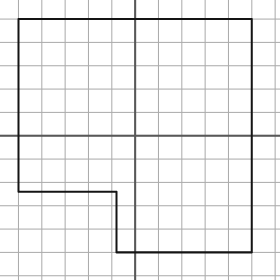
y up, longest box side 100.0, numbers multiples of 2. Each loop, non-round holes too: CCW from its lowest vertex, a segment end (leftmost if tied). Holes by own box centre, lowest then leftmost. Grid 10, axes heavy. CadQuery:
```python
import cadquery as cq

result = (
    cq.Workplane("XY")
    .moveTo(-8.0, -50.0)
    .lineTo(50.0, -50.0)
    .lineTo(50.0, 50.0)
    .lineTo(-50.0, 50.0)
    .lineTo(-50.0, -24.0)
    .lineTo(-8.0, -24.0)
    .close()
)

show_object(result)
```